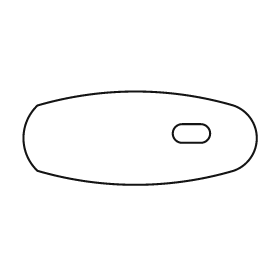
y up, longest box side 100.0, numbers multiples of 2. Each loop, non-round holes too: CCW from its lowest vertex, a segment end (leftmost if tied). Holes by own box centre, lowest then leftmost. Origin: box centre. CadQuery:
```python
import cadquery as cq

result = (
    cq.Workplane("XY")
    .moveTo(-44.0, -14.0)
    .threePointArc((-2.0, -20.0), (40.0, -14.0))
    .threePointArc((50.0, 0.0), (40.0, 14.0))
    .threePointArc((-2.0, 20.0), (-44.0, 14.0))
    .threePointArc((-50.0, 0.0), (-44.0, -14.0))
    .close()
    .moveTo(18.0, -2.0)
    .lineTo(26.0, -2.0)
    .threePointArc((30.0, 2.0), (26.0, 6.0))
    .lineTo(18.0, 6.0)
    .threePointArc((14.0, 2.0), (18.0, -2.0))
    .close()
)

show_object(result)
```